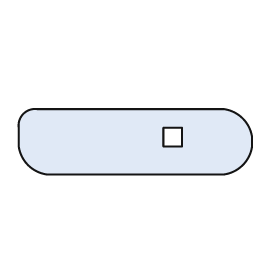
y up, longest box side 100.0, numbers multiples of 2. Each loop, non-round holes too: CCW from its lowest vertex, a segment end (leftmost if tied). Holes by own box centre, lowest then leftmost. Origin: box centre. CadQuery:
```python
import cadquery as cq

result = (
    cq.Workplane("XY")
    .moveTo(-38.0, -14.0)
    .lineTo(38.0, -14.0)
    .threePointArc((46.0, -10.0), (50.0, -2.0))
    .lineTo(50.0, 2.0)
    .threePointArc((46.0, 10.0), (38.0, 14.0))
    .lineTo(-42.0, 14.0)
    .threePointArc((-48.0, 12.0), (-50.0, 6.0))
    .lineTo(-50.0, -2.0)
    .threePointArc((-46.0, -10.0), (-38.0, -14.0))
    .close()
    .moveTo(12.0, -2.0)
    .lineTo(20.0, -2.0)
    .lineTo(20.0, 6.0)
    .lineTo(12.0, 6.0)
    .close()
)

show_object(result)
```